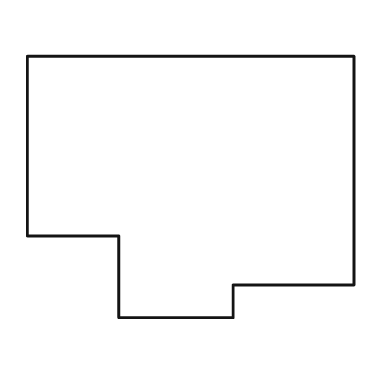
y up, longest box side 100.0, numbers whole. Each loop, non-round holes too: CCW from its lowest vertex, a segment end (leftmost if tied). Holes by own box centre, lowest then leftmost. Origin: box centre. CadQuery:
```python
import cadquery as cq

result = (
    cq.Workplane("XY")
    .moveTo(-22.0, -40.0)
    .lineTo(13.0, -40.0)
    .lineTo(13.0, -30.0)
    .lineTo(50.0, -30.0)
    .lineTo(50.0, 40.0)
    .lineTo(-50.0, 40.0)
    .lineTo(-50.0, -15.0)
    .lineTo(-22.0, -15.0)
    .close()
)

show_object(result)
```